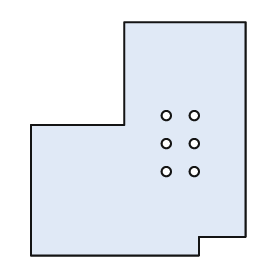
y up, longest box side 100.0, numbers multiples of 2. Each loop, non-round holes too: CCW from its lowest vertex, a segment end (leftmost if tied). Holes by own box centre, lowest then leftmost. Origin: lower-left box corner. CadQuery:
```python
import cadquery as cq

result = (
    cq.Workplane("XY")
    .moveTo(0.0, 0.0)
    .lineTo(72.0, 0.0)
    .lineTo(72.0, 8.0)
    .lineTo(92.0, 8.0)
    .lineTo(92.0, 100.0)
    .lineTo(40.0, 100.0)
    .lineTo(40.0, 56.0)
    .lineTo(0.0, 56.0)
    .close()
    .moveTo(58.0, 36.0)
    .circle(2.0)
    .moveTo(70.0, 36.0)
    .circle(2.0)
    .moveTo(58.0, 48.0)
    .circle(2.0)
    .moveTo(70.0, 48.0)
    .circle(2.0)
    .moveTo(58.0, 60.0)
    .circle(2.0)
    .moveTo(70.0, 60.0)
    .circle(2.0)
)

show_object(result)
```